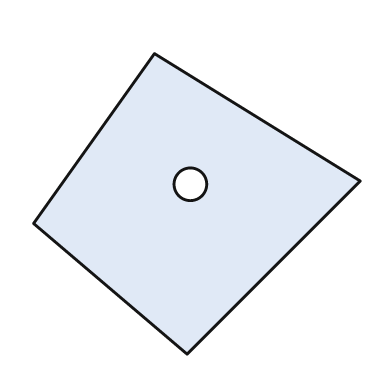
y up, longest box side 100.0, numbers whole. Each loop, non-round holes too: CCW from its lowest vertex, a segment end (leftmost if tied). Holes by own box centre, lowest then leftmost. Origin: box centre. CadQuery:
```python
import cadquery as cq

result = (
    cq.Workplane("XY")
    .moveTo(-3.0, -46.0)
    .lineTo(50.0, 7.0)
    .lineTo(-13.0, 46.0)
    .lineTo(-50.0, -6.0)
    .close()
    .moveTo(-2.0, 6.0)
    .circle(5.0)
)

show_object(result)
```